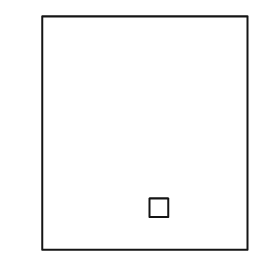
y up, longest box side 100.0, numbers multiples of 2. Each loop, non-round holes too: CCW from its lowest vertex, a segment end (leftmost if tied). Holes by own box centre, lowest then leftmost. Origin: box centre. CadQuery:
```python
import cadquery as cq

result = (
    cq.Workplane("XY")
    .moveTo(-44.0, -50.0)
    .lineTo(44.0, -50.0)
    .lineTo(44.0, 50.0)
    .lineTo(-44.0, 50.0)
    .close()
    .moveTo(2.0, -36.0)
    .lineTo(10.0, -36.0)
    .lineTo(10.0, -28.0)
    .lineTo(2.0, -28.0)
    .close()
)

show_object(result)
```